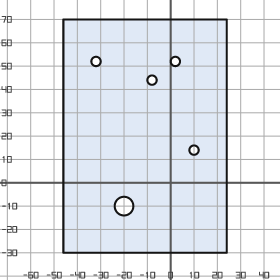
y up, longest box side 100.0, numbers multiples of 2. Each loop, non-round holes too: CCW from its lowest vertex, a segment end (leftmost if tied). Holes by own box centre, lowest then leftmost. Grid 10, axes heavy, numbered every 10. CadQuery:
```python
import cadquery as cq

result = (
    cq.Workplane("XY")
    .moveTo(-46.0, -30.0)
    .lineTo(24.0, -30.0)
    .lineTo(24.0, 70.0)
    .lineTo(-46.0, 70.0)
    .close()
    .moveTo(-20.0, -10.0)
    .circle(4.0)
    .moveTo(10.0, 14.0)
    .circle(2.0)
    .moveTo(-8.0, 44.0)
    .circle(2.0)
    .moveTo(-32.0, 52.0)
    .circle(2.0)
    .moveTo(2.0, 52.0)
    .circle(2.0)
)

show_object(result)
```